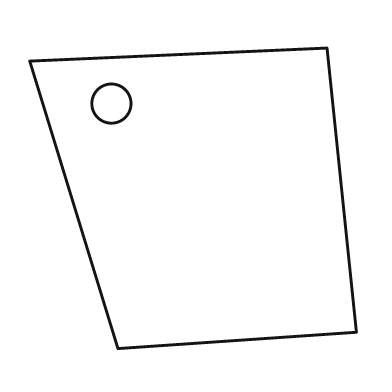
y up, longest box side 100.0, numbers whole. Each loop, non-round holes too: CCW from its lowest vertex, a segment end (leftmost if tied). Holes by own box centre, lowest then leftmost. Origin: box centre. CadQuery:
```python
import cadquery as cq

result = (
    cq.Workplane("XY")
    .moveTo(-23.0, -46.0)
    .lineTo(50.0, -41.0)
    .lineTo(41.0, 46.0)
    .lineTo(-50.0, 42.0)
    .close()
    .moveTo(-25.0, 29.0)
    .circle(6.0)
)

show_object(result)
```